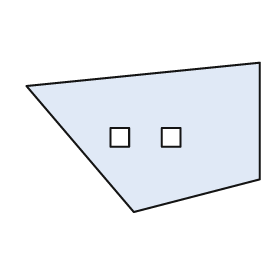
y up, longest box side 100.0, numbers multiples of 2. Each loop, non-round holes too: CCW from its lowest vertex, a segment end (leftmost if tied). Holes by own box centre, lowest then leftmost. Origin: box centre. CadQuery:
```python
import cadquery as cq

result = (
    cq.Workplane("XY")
    .moveTo(-4.0, -32.0)
    .lineTo(50.0, -18.0)
    .lineTo(50.0, 32.0)
    .lineTo(-50.0, 22.0)
    .close()
    .moveTo(-14.0, -4.0)
    .lineTo(-6.0, -4.0)
    .lineTo(-6.0, 4.0)
    .lineTo(-14.0, 4.0)
    .close()
    .moveTo(8.0, -4.0)
    .lineTo(16.0, -4.0)
    .lineTo(16.0, 4.0)
    .lineTo(8.0, 4.0)
    .close()
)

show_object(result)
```